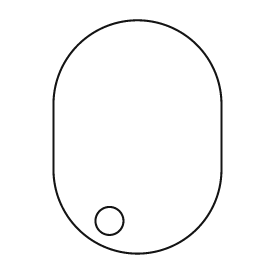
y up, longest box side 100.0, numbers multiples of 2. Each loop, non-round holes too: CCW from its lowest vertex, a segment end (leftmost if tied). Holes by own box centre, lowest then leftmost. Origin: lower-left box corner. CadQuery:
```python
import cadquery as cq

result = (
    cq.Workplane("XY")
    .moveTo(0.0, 36.0)
    .threePointArc((36.0, 0.0), (72.0, 36.0))
    .lineTo(72.0, 64.0)
    .threePointArc((36.0, 100.0), (0.0, 64.0))
    .close()
    .moveTo(24.0, 14.0)
    .circle(6.0)
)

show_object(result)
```